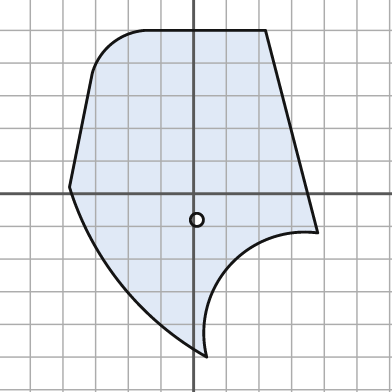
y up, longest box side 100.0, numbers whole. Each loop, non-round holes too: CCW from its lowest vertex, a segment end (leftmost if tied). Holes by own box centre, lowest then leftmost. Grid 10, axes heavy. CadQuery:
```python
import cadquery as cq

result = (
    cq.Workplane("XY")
    .moveTo(4.0, -50.0)
    .threePointArc((11.0, -22.0), (38.0, -12.0))
    .lineTo(22.0, 50.0)
    .lineTo(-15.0, 50.0)
    .threePointArc((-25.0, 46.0), (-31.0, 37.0))
    .lineTo(-38.0, 2.0)
    .threePointArc((-22.0, -28.0), (4.0, -50.0))
    .close()
    .moveTo(1.0, -8.0)
    .circle(2.0)
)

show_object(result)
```